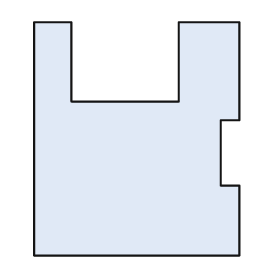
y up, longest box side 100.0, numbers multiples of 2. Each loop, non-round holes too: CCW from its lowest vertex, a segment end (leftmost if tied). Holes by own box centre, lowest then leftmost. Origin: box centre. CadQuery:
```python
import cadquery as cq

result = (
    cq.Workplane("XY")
    .moveTo(-44.0, -50.0)
    .lineTo(44.0, -50.0)
    .lineTo(44.0, -20.0)
    .lineTo(36.0, -20.0)
    .lineTo(36.0, 8.0)
    .lineTo(44.0, 8.0)
    .lineTo(44.0, 50.0)
    .lineTo(18.0, 50.0)
    .lineTo(18.0, 16.0)
    .lineTo(-28.0, 16.0)
    .lineTo(-28.0, 50.0)
    .lineTo(-44.0, 50.0)
    .close()
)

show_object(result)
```